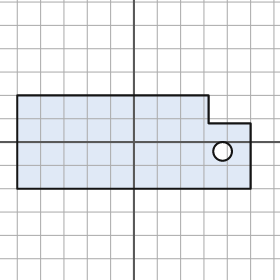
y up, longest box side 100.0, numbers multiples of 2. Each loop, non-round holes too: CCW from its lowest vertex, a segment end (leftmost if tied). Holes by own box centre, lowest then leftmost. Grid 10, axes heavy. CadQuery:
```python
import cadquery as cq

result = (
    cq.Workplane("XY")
    .moveTo(-50.0, -20.0)
    .lineTo(50.0, -20.0)
    .lineTo(50.0, 8.0)
    .lineTo(32.0, 8.0)
    .lineTo(32.0, 20.0)
    .lineTo(-50.0, 20.0)
    .close()
    .moveTo(38.0, -4.0)
    .circle(4.0)
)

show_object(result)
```